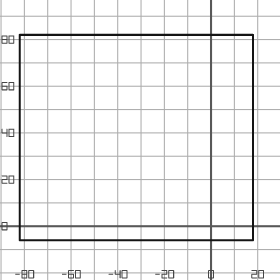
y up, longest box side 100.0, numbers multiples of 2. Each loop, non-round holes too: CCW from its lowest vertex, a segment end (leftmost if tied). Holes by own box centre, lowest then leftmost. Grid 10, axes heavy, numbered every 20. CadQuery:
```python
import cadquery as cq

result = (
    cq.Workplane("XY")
    .moveTo(-82.0, -6.0)
    .lineTo(18.0, -6.0)
    .lineTo(18.0, 82.0)
    .lineTo(-82.0, 82.0)
    .close()
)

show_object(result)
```